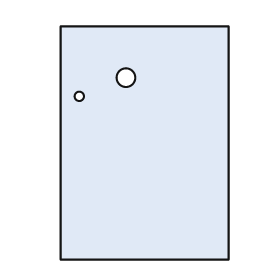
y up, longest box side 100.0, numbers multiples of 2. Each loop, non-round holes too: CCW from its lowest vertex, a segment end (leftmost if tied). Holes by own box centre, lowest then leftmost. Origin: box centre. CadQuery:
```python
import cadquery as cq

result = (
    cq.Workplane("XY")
    .moveTo(-36.0, -50.0)
    .lineTo(36.0, -50.0)
    .lineTo(36.0, 50.0)
    .lineTo(-36.0, 50.0)
    .close()
    .moveTo(-28.0, 20.0)
    .circle(2.0)
    .moveTo(-8.0, 28.0)
    .circle(4.0)
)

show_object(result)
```